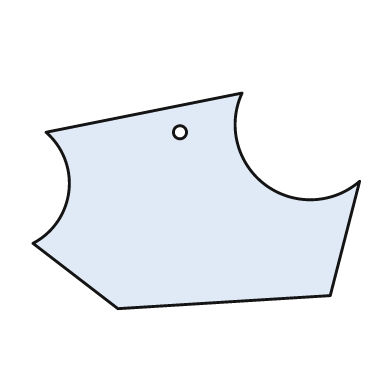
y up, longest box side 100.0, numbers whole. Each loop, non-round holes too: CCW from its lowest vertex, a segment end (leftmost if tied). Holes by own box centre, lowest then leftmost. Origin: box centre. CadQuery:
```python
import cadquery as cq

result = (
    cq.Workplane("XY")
    .moveTo(-24.0, -33.0)
    .lineTo(41.0, -29.0)
    .lineTo(50.0, 6.0)
    .threePointArc((21.0, 5.0), (14.0, 33.0))
    .lineTo(-46.0, 21.0)
    .threePointArc((-39.0, 3.0), (-50.0, -13.0))
    .close()
    .moveTo(-5.0, 21.0)
    .circle(2.0)
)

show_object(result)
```